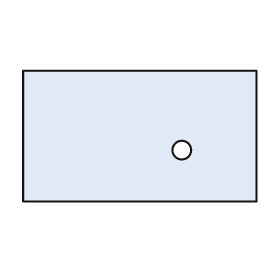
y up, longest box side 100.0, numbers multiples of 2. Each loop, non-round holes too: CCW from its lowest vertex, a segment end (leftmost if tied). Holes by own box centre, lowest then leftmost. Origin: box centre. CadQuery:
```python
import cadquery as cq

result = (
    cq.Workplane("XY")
    .moveTo(-50.0, -28.0)
    .lineTo(50.0, -28.0)
    .lineTo(50.0, 28.0)
    .lineTo(-50.0, 28.0)
    .close()
    .moveTo(18.0, -6.0)
    .circle(4.0)
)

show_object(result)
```